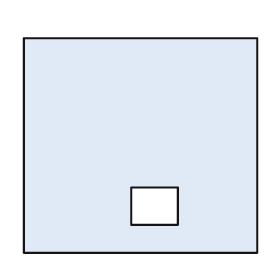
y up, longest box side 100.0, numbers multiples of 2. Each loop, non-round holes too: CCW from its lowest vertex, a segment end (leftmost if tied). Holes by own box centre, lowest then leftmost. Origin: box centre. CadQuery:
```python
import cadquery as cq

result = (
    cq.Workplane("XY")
    .moveTo(-50.0, -46.0)
    .lineTo(50.0, -46.0)
    .lineTo(50.0, 46.0)
    .lineTo(-50.0, 46.0)
    .close()
    .moveTo(-4.0, -34.0)
    .lineTo(16.0, -34.0)
    .lineTo(16.0, -18.0)
    .lineTo(-4.0, -18.0)
    .close()
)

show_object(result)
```